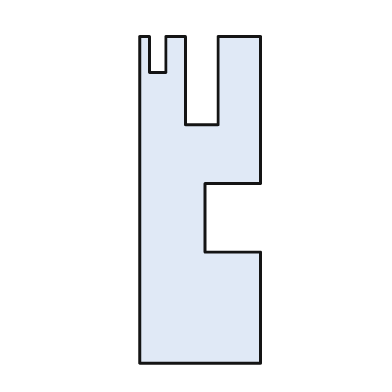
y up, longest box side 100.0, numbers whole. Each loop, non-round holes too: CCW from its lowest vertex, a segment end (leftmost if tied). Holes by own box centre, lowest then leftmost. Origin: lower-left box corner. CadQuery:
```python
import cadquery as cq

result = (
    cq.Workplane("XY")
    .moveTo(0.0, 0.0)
    .lineTo(37.0, 0.0)
    .lineTo(37.0, 34.0)
    .lineTo(20.0, 34.0)
    .lineTo(20.0, 55.0)
    .lineTo(37.0, 55.0)
    .lineTo(37.0, 100.0)
    .lineTo(24.0, 100.0)
    .lineTo(24.0, 73.0)
    .lineTo(14.0, 73.0)
    .lineTo(14.0, 100.0)
    .lineTo(8.0, 100.0)
    .lineTo(8.0, 89.0)
    .lineTo(3.0, 89.0)
    .lineTo(3.0, 100.0)
    .lineTo(0.0, 100.0)
    .close()
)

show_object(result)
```